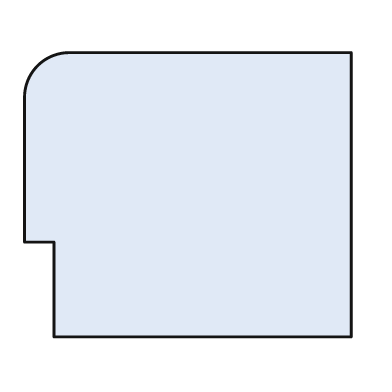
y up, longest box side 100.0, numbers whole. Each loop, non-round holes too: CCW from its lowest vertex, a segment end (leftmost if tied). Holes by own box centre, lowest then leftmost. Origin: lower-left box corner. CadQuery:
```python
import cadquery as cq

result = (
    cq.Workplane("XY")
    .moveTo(9.0, 0.0)
    .lineTo(100.0, 0.0)
    .lineTo(100.0, 87.0)
    .lineTo(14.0, 87.0)
    .threePointArc((4.0, 83.0), (0.0, 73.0))
    .lineTo(0.0, 29.0)
    .lineTo(9.0, 29.0)
    .close()
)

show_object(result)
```